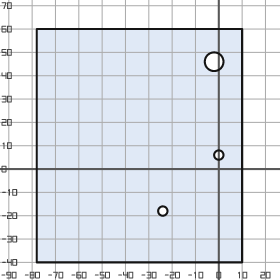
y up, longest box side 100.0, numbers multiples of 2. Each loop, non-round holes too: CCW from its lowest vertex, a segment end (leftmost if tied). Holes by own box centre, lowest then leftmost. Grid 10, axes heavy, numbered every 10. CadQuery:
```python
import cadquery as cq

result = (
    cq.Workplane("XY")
    .moveTo(-78.0, -40.0)
    .lineTo(10.0, -40.0)
    .lineTo(10.0, 60.0)
    .lineTo(-78.0, 60.0)
    .close()
    .moveTo(-24.0, -18.0)
    .circle(2.0)
    .moveTo(0.0, 6.0)
    .circle(2.0)
    .moveTo(-2.0, 46.0)
    .circle(4.0)
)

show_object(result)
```